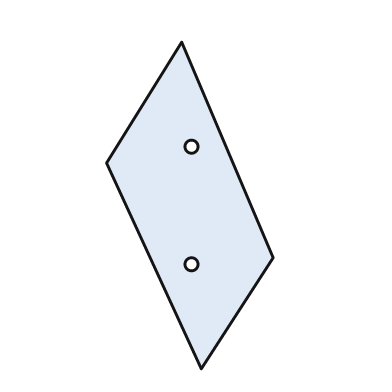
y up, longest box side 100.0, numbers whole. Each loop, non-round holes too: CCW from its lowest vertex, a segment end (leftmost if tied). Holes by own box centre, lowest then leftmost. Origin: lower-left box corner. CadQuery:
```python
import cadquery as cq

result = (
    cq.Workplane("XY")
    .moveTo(29.0, 0.0)
    .lineTo(51.0, 34.0)
    .lineTo(23.0, 100.0)
    .lineTo(0.0, 63.0)
    .close()
    .moveTo(26.0, 32.0)
    .circle(2.0)
    .moveTo(26.0, 68.0)
    .circle(2.0)
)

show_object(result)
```